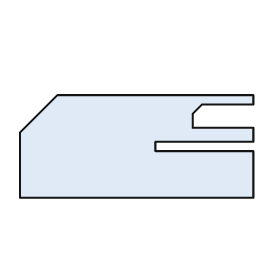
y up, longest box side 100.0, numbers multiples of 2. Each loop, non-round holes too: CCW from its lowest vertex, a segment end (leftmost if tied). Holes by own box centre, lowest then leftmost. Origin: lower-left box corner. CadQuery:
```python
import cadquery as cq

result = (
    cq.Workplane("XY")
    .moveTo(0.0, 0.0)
    .lineTo(100.0, 0.0)
    .lineTo(100.0, 20.0)
    .lineTo(58.0, 20.0)
    .lineTo(58.0, 24.0)
    .lineTo(100.0, 24.0)
    .lineTo(100.0, 30.0)
    .lineTo(74.0, 30.0)
    .lineTo(74.0, 36.0)
    .lineTo(78.0, 40.0)
    .lineTo(100.0, 40.0)
    .lineTo(100.0, 44.0)
    .lineTo(16.0, 44.0)
    .lineTo(0.0, 28.0)
    .close()
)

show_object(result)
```